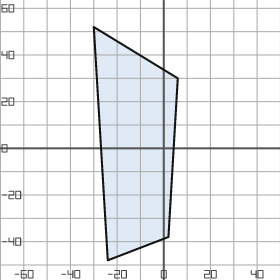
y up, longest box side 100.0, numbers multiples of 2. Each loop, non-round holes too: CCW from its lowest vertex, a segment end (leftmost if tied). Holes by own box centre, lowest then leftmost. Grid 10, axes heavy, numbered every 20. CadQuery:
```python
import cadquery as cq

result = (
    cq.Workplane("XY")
    .moveTo(-24.0, -48.0)
    .lineTo(2.0, -38.0)
    .lineTo(6.0, 30.0)
    .lineTo(-30.0, 52.0)
    .close()
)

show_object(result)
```